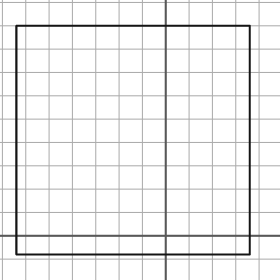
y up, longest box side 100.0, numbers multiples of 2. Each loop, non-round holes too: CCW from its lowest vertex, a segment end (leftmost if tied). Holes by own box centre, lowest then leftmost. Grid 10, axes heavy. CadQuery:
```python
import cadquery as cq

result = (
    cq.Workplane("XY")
    .moveTo(-64.0, -8.0)
    .lineTo(36.0, -8.0)
    .lineTo(36.0, 90.0)
    .lineTo(-64.0, 90.0)
    .close()
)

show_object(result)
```